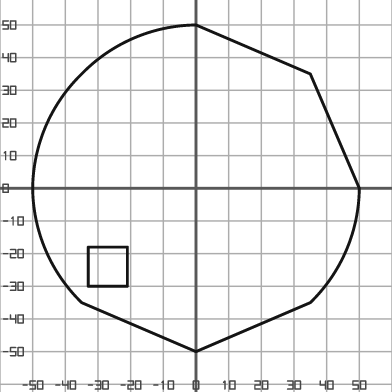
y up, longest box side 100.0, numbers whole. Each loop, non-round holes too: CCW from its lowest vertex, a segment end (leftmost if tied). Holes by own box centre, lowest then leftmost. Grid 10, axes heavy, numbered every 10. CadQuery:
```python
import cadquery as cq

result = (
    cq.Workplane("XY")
    .moveTo(0.0, -50.0)
    .lineTo(35.0, -35.0)
    .threePointArc((46.0, -19.0), (50.0, 0.0))
    .lineTo(35.0, 35.0)
    .lineTo(0.0, 50.0)
    .threePointArc((-19.0, 46.0), (-35.0, 35.0))
    .threePointArc((-46.0, 19.0), (-50.0, 0.0))
    .threePointArc((-46.0, -19.0), (-35.0, -35.0))
    .close()
    .moveTo(-33.0, -30.0)
    .lineTo(-21.0, -30.0)
    .lineTo(-21.0, -18.0)
    .lineTo(-33.0, -18.0)
    .close()
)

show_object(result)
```